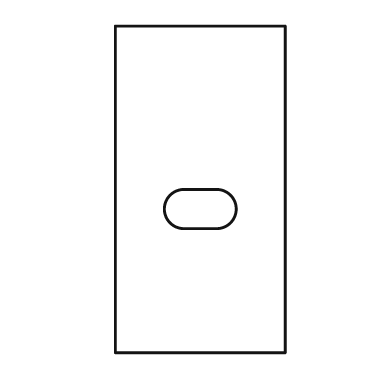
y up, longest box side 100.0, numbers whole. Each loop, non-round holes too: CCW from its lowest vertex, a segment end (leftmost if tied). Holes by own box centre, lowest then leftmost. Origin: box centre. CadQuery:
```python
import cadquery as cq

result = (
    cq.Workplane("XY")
    .moveTo(-26.0, -50.0)
    .lineTo(26.0, -50.0)
    .lineTo(26.0, 50.0)
    .lineTo(-26.0, 50.0)
    .close()
    .moveTo(-5.0, -12.0)
    .lineTo(5.0, -12.0)
    .threePointArc((11.0, -6.0), (5.0, 0.0))
    .lineTo(-5.0, 0.0)
    .threePointArc((-11.0, -6.0), (-5.0, -12.0))
    .close()
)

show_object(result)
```